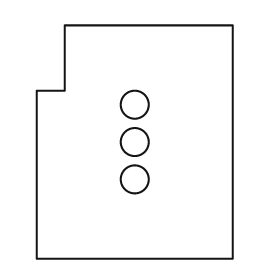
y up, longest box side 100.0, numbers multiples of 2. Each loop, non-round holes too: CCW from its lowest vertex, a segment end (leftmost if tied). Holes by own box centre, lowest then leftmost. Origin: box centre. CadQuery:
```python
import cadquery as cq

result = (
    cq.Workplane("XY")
    .moveTo(-42.0, -50.0)
    .lineTo(42.0, -50.0)
    .lineTo(42.0, 50.0)
    .lineTo(-30.0, 50.0)
    .lineTo(-30.0, 22.0)
    .lineTo(-42.0, 22.0)
    .close()
    .moveTo(0.0, -16.0)
    .circle(6.0)
    .moveTo(0.0, 0.0)
    .circle(6.0)
    .moveTo(0.0, 16.0)
    .circle(6.0)
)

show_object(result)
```